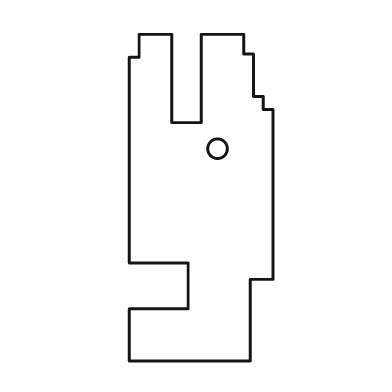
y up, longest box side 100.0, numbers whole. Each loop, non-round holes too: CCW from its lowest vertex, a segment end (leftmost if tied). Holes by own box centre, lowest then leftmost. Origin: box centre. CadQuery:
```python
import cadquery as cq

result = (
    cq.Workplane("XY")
    .moveTo(-22.0, -50.0)
    .lineTo(15.0, -50.0)
    .lineTo(15.0, -25.0)
    .lineTo(22.0, -25.0)
    .lineTo(22.0, 27.0)
    .lineTo(19.0, 27.0)
    .lineTo(19.0, 31.0)
    .lineTo(16.0, 31.0)
    .lineTo(16.0, 44.0)
    .lineTo(13.0, 44.0)
    .lineTo(13.0, 50.0)
    .lineTo(0.0, 50.0)
    .lineTo(0.0, 23.0)
    .lineTo(-9.0, 23.0)
    .lineTo(-9.0, 50.0)
    .lineTo(-19.0, 50.0)
    .lineTo(-19.0, 43.0)
    .lineTo(-22.0, 43.0)
    .lineTo(-22.0, -20.0)
    .lineTo(-4.0, -20.0)
    .lineTo(-4.0, -34.0)
    .lineTo(-22.0, -34.0)
    .close()
    .moveTo(5.0, 15.0)
    .circle(3.0)
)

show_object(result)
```